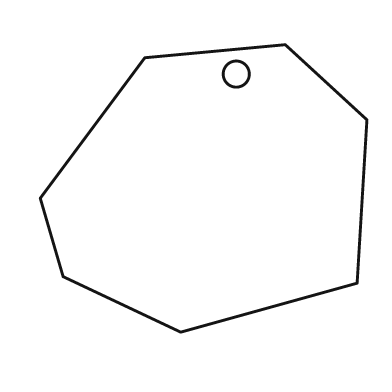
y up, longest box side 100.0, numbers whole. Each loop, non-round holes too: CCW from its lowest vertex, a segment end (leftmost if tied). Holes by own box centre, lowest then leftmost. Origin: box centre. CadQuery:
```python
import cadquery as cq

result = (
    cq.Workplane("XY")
    .moveTo(-7.0, -44.0)
    .lineTo(47.0, -29.0)
    .lineTo(50.0, 21.0)
    .lineTo(25.0, 44.0)
    .lineTo(-18.0, 40.0)
    .lineTo(-50.0, -3.0)
    .lineTo(-43.0, -27.0)
    .close()
    .moveTo(10.0, 35.0)
    .circle(4.0)
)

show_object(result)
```